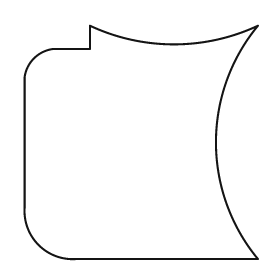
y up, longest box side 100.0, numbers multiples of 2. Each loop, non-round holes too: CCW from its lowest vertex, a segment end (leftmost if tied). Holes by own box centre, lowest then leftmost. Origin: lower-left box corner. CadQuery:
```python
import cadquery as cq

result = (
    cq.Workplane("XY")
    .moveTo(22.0, 0.0)
    .lineTo(100.0, 0.0)
    .threePointArc((82.0, 50.0), (100.0, 100.0))
    .threePointArc((64.0, 92.0), (28.0, 100.0))
    .lineTo(28.0, 90.0)
    .lineTo(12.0, 90.0)
    .threePointArc((4.0, 86.0), (0.0, 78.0))
    .lineTo(0.0, 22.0)
    .threePointArc((6.0, 6.0), (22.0, 0.0))
    .close()
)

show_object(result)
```